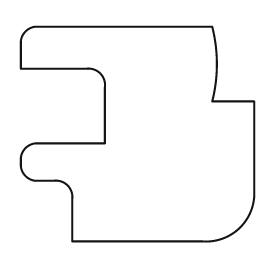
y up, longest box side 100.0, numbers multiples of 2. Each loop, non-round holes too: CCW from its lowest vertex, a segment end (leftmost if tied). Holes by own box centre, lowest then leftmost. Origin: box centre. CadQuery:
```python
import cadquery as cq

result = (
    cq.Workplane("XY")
    .moveTo(-28.0, -46.0)
    .lineTo(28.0, -46.0)
    .threePointArc((44.0, -40.0), (50.0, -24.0))
    .lineTo(50.0, 14.0)
    .lineTo(32.0, 14.0)
    .threePointArc((34.0, 30.0), (32.0, 46.0))
    .lineTo(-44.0, 46.0)
    .threePointArc((-48.0, 44.0), (-50.0, 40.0))
    .lineTo(-50.0, 28.0)
    .lineTo(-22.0, 28.0)
    .threePointArc((-16.0, 26.0), (-14.0, 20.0))
    .lineTo(-14.0, -4.0)
    .lineTo(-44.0, -4.0)
    .threePointArc((-48.0, -6.0), (-50.0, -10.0))
    .lineTo(-50.0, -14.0)
    .threePointArc((-48.0, -18.0), (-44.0, -20.0))
    .lineTo(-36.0, -20.0)
    .threePointArc((-30.0, -22.0), (-28.0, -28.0))
    .close()
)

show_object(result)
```